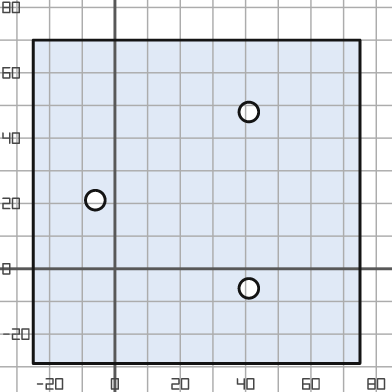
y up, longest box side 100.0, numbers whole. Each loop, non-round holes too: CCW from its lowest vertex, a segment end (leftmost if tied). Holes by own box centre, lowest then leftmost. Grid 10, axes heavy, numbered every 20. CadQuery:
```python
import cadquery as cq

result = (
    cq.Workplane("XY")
    .moveTo(-25.0, -29.0)
    .lineTo(75.0, -29.0)
    .lineTo(75.0, 70.0)
    .lineTo(-25.0, 70.0)
    .close()
    .moveTo(41.0, -6.0)
    .circle(3.0)
    .moveTo(-6.0, 21.0)
    .circle(3.0)
    .moveTo(41.0, 48.0)
    .circle(3.0)
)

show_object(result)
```